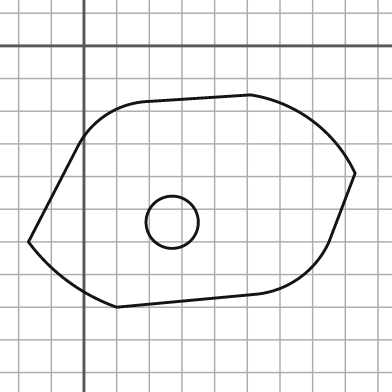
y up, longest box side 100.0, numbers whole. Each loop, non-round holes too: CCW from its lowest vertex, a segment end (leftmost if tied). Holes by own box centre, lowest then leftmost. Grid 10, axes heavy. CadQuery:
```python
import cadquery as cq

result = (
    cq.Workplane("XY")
    .moveTo(10.0, -80.0)
    .lineTo(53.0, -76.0)
    .threePointArc((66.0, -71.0), (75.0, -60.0))
    .lineTo(83.0, -39.0)
    .threePointArc((70.0, -23.0), (51.0, -15.0))
    .lineTo(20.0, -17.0)
    .threePointArc((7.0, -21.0), (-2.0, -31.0))
    .lineTo(-17.0, -60.0)
    .threePointArc((-5.0, -72.0), (10.0, -80.0))
    .close()
    .moveTo(27.0, -54.0)
    .circle(8.0)
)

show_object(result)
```